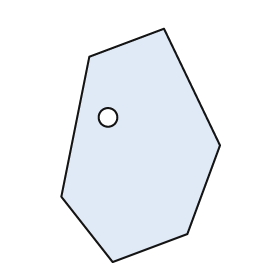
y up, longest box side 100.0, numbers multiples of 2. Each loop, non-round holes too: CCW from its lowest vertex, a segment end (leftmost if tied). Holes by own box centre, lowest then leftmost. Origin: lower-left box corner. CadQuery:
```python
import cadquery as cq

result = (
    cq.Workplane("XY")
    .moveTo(22.0, 0.0)
    .lineTo(54.0, 12.0)
    .lineTo(68.0, 50.0)
    .lineTo(44.0, 100.0)
    .lineTo(12.0, 88.0)
    .lineTo(0.0, 28.0)
    .close()
    .moveTo(20.0, 62.0)
    .circle(4.0)
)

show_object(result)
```